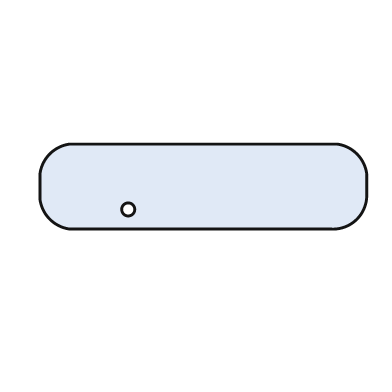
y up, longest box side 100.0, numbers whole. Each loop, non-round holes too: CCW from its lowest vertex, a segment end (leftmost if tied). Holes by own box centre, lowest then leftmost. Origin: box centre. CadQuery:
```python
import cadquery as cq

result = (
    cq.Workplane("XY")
    .moveTo(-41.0, -13.0)
    .lineTo(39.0, -13.0)
    .threePointArc((47.0, -10.0), (50.0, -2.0))
    .lineTo(50.0, 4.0)
    .threePointArc((47.0, 10.0), (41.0, 13.0))
    .lineTo(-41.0, 13.0)
    .threePointArc((-47.0, 10.0), (-50.0, 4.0))
    .lineTo(-50.0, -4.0)
    .threePointArc((-47.0, -10.0), (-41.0, -13.0))
    .close()
    .moveTo(-23.0, -7.0)
    .circle(2.0)
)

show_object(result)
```